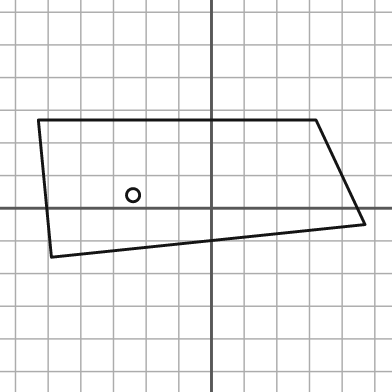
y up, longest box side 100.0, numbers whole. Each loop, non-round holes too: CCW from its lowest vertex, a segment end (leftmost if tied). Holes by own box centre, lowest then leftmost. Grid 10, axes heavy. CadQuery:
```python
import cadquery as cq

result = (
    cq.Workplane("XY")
    .moveTo(-49.0, -15.0)
    .lineTo(47.0, -5.0)
    .lineTo(32.0, 27.0)
    .lineTo(-53.0, 27.0)
    .close()
    .moveTo(-24.0, 4.0)
    .circle(2.0)
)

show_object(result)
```